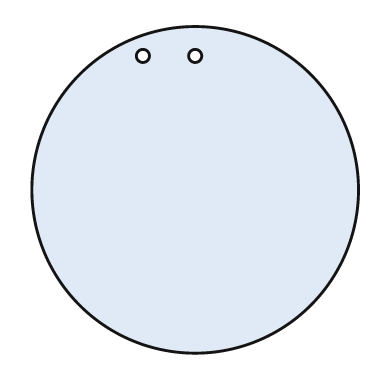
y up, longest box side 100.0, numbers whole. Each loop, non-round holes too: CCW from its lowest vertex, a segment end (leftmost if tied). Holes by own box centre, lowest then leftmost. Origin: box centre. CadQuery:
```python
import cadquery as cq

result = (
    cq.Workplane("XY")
    .moveTo(0.0, 0.0)
    .circle(50.0)
    .moveTo(-16.0, 41.0)
    .circle(2.0)
    .moveTo(0.0, 41.0)
    .circle(2.0)
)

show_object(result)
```